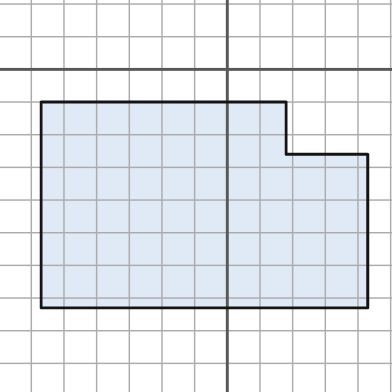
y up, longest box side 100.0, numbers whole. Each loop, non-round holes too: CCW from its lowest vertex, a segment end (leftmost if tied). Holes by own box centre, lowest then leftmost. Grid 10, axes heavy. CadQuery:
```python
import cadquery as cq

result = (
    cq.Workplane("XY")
    .moveTo(-57.0, -73.0)
    .lineTo(43.0, -73.0)
    .lineTo(43.0, -26.0)
    .lineTo(18.0, -26.0)
    .lineTo(18.0, -10.0)
    .lineTo(-57.0, -10.0)
    .close()
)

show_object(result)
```